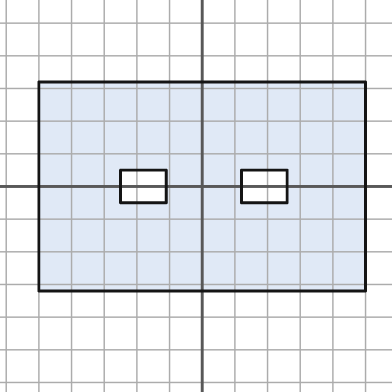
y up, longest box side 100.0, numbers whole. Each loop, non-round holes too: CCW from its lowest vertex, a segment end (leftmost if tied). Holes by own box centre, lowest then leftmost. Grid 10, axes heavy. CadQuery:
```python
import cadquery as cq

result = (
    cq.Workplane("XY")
    .moveTo(-50.0, -32.0)
    .lineTo(50.0, -32.0)
    .lineTo(50.0, 32.0)
    .lineTo(-50.0, 32.0)
    .close()
    .moveTo(-25.0, -5.0)
    .lineTo(-11.0, -5.0)
    .lineTo(-11.0, 5.0)
    .lineTo(-25.0, 5.0)
    .close()
    .moveTo(12.0, -5.0)
    .lineTo(26.0, -5.0)
    .lineTo(26.0, 5.0)
    .lineTo(12.0, 5.0)
    .close()
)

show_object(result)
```